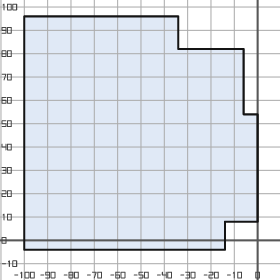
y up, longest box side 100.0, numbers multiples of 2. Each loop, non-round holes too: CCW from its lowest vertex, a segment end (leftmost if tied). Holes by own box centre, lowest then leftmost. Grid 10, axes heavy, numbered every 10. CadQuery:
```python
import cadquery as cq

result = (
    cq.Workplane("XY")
    .moveTo(-100.0, -4.0)
    .lineTo(-14.0, -4.0)
    .lineTo(-14.0, 8.0)
    .lineTo(0.0, 8.0)
    .lineTo(0.0, 54.0)
    .lineTo(-6.0, 54.0)
    .lineTo(-6.0, 82.0)
    .lineTo(-34.0, 82.0)
    .lineTo(-34.0, 96.0)
    .lineTo(-100.0, 96.0)
    .close()
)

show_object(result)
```